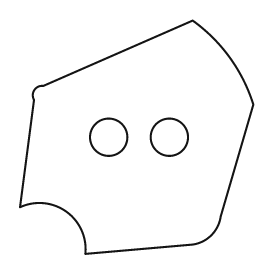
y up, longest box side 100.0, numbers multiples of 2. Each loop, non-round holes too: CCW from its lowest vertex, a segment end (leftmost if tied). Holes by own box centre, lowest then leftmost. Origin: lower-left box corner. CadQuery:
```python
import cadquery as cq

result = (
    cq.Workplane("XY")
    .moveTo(28.0, 0.0)
    .lineTo(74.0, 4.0)
    .threePointArc((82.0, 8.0), (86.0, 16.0))
    .lineTo(100.0, 64.0)
    .threePointArc((90.0, 84.0), (74.0, 100.0))
    .lineTo(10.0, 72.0)
    .threePointArc((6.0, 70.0), (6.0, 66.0))
    .lineTo(0.0, 20.0)
    .threePointArc((20.0, 18.0), (28.0, 0.0))
    .close()
    .moveTo(38.0, 50.0)
    .circle(8.0)
    .moveTo(64.0, 50.0)
    .circle(8.0)
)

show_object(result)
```